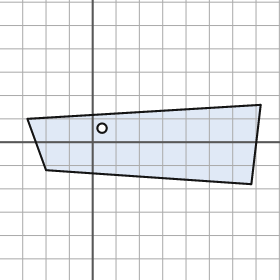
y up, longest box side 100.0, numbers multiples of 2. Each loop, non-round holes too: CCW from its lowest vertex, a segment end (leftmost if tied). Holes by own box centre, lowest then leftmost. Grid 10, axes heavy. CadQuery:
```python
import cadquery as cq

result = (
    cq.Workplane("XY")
    .moveTo(68.0, -18.0)
    .lineTo(72.0, 16.0)
    .lineTo(-28.0, 10.0)
    .lineTo(-20.0, -12.0)
    .close()
    .moveTo(4.0, 6.0)
    .circle(2.0)
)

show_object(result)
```